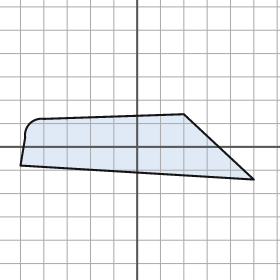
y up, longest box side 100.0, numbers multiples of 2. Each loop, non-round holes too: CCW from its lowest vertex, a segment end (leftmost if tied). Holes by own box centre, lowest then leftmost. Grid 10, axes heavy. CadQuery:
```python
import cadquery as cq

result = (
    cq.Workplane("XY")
    .moveTo(50.0, -14.0)
    .lineTo(20.0, 14.0)
    .lineTo(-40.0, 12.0)
    .threePointArc((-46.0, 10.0), (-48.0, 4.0))
    .lineTo(-50.0, -8.0)
    .close()
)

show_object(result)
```